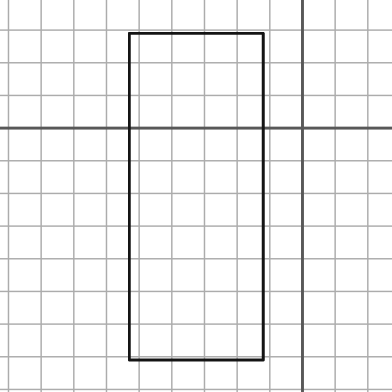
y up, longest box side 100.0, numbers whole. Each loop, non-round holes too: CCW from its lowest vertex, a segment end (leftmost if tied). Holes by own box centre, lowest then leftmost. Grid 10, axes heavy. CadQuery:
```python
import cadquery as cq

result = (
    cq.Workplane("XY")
    .moveTo(-53.0, -71.0)
    .lineTo(-12.0, -71.0)
    .lineTo(-12.0, 29.0)
    .lineTo(-53.0, 29.0)
    .close()
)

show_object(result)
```